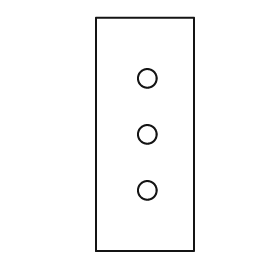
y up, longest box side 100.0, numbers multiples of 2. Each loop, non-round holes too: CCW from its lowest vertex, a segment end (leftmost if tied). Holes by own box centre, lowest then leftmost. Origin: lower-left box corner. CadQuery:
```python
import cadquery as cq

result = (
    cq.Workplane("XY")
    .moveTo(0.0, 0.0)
    .lineTo(42.0, 0.0)
    .lineTo(42.0, 100.0)
    .lineTo(0.0, 100.0)
    .close()
    .moveTo(22.0, 26.0)
    .circle(4.0)
    .moveTo(22.0, 50.0)
    .circle(4.0)
    .moveTo(22.0, 74.0)
    .circle(4.0)
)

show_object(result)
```